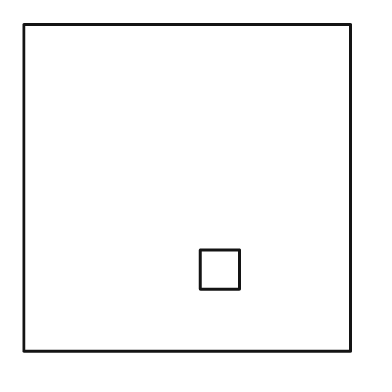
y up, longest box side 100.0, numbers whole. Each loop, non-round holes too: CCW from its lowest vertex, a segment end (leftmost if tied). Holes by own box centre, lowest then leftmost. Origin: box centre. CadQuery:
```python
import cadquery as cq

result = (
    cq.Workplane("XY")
    .moveTo(-50.0, -50.0)
    .lineTo(50.0, -50.0)
    .lineTo(50.0, 50.0)
    .lineTo(-50.0, 50.0)
    .close()
    .moveTo(4.0, -31.0)
    .lineTo(16.0, -31.0)
    .lineTo(16.0, -19.0)
    .lineTo(4.0, -19.0)
    .close()
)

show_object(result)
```